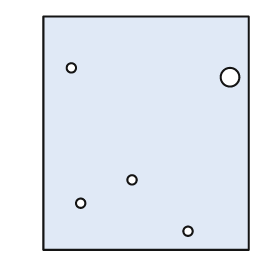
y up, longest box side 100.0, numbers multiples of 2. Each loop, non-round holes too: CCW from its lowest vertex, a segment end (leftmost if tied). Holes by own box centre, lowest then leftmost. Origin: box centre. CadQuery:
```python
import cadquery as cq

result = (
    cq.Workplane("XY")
    .moveTo(-44.0, -50.0)
    .lineTo(44.0, -50.0)
    .lineTo(44.0, 50.0)
    .lineTo(-44.0, 50.0)
    .close()
    .moveTo(18.0, -42.0)
    .circle(2.0)
    .moveTo(-28.0, -30.0)
    .circle(2.0)
    .moveTo(-6.0, -20.0)
    .circle(2.0)
    .moveTo(36.0, 24.0)
    .circle(4.0)
    .moveTo(-32.0, 28.0)
    .circle(2.0)
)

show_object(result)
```